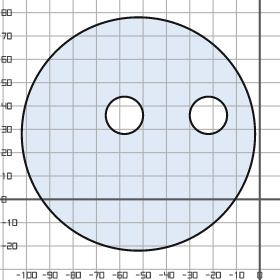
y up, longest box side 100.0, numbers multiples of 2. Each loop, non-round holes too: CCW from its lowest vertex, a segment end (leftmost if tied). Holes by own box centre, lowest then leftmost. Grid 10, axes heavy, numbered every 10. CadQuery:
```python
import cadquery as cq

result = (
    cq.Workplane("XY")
    .moveTo(-52.0, 28.0)
    .circle(50.0)
    .moveTo(-58.0, 36.0)
    .circle(8.0)
    .moveTo(-22.0, 36.0)
    .circle(8.0)
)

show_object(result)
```